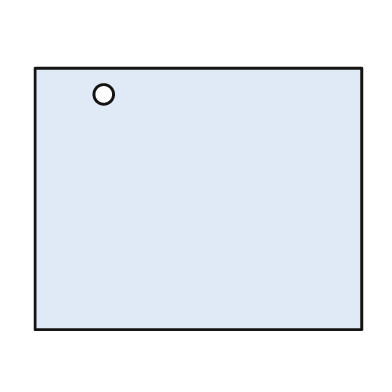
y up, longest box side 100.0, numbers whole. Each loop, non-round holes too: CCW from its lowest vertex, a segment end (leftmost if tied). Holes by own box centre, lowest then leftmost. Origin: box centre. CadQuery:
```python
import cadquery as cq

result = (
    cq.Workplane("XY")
    .moveTo(-50.0, -40.0)
    .lineTo(50.0, -40.0)
    .lineTo(50.0, 40.0)
    .lineTo(-50.0, 40.0)
    .close()
    .moveTo(-29.0, 32.0)
    .circle(3.0)
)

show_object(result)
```